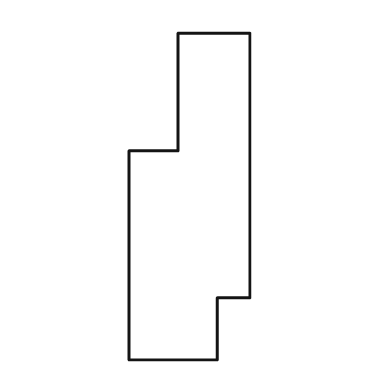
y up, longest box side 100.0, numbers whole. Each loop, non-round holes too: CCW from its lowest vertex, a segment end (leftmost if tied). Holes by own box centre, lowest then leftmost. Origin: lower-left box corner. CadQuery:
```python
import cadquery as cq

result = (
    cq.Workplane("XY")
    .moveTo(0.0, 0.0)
    .lineTo(27.0, 0.0)
    .lineTo(27.0, 19.0)
    .lineTo(37.0, 19.0)
    .lineTo(37.0, 100.0)
    .lineTo(15.0, 100.0)
    .lineTo(15.0, 64.0)
    .lineTo(0.0, 64.0)
    .close()
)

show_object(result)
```